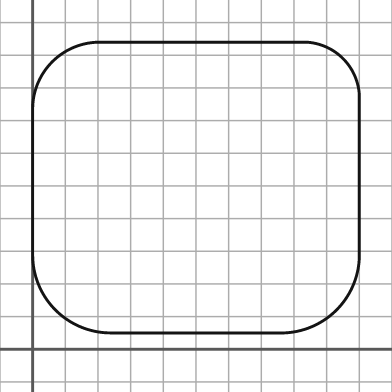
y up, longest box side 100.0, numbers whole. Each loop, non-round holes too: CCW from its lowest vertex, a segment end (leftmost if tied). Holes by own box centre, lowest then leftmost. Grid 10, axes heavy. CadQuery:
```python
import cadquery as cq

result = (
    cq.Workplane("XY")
    .moveTo(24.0, 5.0)
    .lineTo(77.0, 5.0)
    .threePointArc((93.0, 12.0), (100.0, 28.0))
    .lineTo(100.0, 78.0)
    .threePointArc((95.0, 89.0), (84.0, 94.0))
    .lineTo(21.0, 94.0)
    .threePointArc((6.0, 88.0), (0.0, 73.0))
    .lineTo(0.0, 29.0)
    .threePointArc((7.0, 12.0), (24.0, 5.0))
    .close()
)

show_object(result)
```